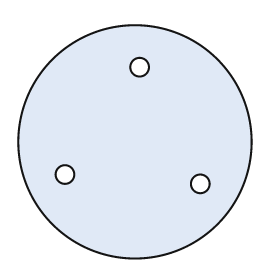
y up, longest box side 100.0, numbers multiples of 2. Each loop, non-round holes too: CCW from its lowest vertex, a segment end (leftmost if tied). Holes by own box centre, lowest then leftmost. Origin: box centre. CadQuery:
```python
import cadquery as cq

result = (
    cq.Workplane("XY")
    .moveTo(0.0, 0.0)
    .circle(50.0)
    .moveTo(28.0, -18.0)
    .circle(4.0)
    .moveTo(-30.0, -14.0)
    .circle(4.0)
    .moveTo(2.0, 32.0)
    .circle(4.0)
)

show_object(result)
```